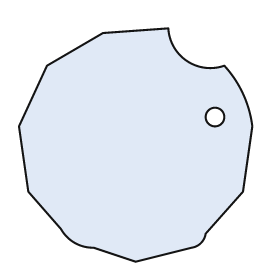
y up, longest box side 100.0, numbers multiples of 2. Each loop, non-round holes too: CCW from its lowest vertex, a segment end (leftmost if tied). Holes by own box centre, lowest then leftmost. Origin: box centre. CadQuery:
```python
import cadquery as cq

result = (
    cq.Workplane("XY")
    .moveTo(0.0, -50.0)
    .lineTo(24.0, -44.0)
    .threePointArc((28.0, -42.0), (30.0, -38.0))
    .lineTo(46.0, -20.0)
    .lineTo(50.0, 8.0)
    .threePointArc((46.0, 22.0), (38.0, 34.0))
    .threePointArc((22.0, 36.0), (14.0, 50.0))
    .lineTo(-14.0, 48.0)
    .lineTo(-38.0, 34.0)
    .lineTo(-50.0, 8.0)
    .lineTo(-46.0, -20.0)
    .lineTo(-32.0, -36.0)
    .threePointArc((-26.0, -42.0), (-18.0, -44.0))
    .close()
    .moveTo(34.0, 12.0)
    .circle(4.0)
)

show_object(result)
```